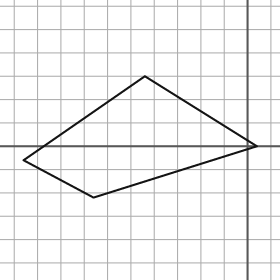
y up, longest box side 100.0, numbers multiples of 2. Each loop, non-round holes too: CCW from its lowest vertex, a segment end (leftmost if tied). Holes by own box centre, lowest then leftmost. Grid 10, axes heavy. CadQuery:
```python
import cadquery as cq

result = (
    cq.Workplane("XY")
    .moveTo(-66.0, -22.0)
    .lineTo(4.0, 0.0)
    .lineTo(-44.0, 30.0)
    .lineTo(-96.0, -6.0)
    .close()
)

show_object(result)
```